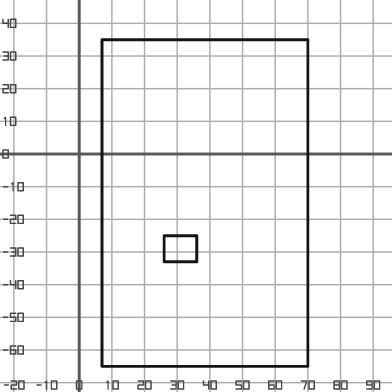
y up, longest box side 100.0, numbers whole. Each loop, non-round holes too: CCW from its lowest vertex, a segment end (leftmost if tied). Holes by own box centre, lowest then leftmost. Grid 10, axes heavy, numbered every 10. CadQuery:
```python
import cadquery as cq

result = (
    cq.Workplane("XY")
    .moveTo(7.0, -65.0)
    .lineTo(70.0, -65.0)
    .lineTo(70.0, 35.0)
    .lineTo(7.0, 35.0)
    .close()
    .moveTo(26.0, -33.0)
    .lineTo(36.0, -33.0)
    .lineTo(36.0, -25.0)
    .lineTo(26.0, -25.0)
    .close()
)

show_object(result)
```